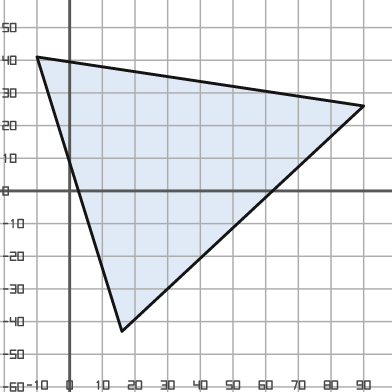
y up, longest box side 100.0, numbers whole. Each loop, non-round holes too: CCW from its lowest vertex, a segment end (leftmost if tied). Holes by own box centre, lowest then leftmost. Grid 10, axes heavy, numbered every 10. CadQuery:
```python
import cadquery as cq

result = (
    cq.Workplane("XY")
    .moveTo(16.0, -43.0)
    .lineTo(90.0, 26.0)
    .lineTo(-10.0, 41.0)
    .close()
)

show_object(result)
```